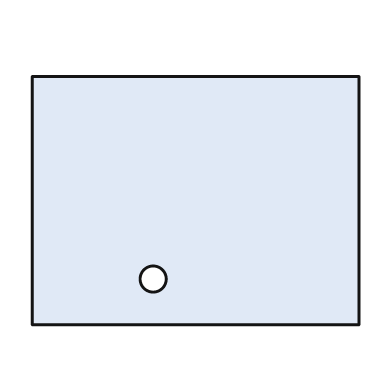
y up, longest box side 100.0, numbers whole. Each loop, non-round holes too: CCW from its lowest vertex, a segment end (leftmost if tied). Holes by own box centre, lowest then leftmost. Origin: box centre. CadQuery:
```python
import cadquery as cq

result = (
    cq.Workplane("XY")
    .moveTo(-50.0, -38.0)
    .lineTo(50.0, -38.0)
    .lineTo(50.0, 38.0)
    .lineTo(-50.0, 38.0)
    .close()
    .moveTo(-13.0, -24.0)
    .circle(4.0)
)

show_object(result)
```